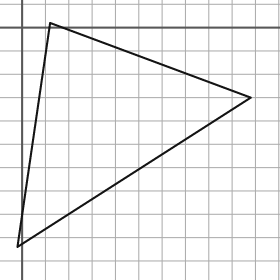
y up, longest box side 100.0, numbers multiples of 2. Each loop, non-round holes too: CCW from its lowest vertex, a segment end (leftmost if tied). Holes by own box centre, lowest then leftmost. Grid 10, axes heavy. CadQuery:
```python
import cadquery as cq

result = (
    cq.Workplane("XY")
    .moveTo(-2.0, -94.0)
    .lineTo(98.0, -30.0)
    .lineTo(12.0, 2.0)
    .close()
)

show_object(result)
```